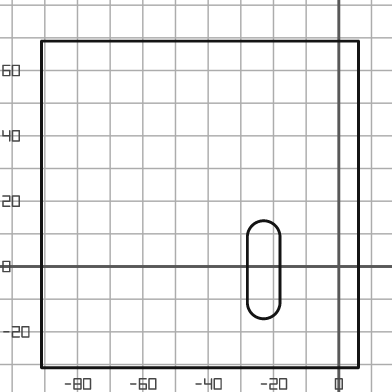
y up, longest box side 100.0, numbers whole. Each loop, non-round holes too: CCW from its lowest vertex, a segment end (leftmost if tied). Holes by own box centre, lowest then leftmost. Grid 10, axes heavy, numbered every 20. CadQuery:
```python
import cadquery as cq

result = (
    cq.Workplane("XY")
    .moveTo(-91.0, -31.0)
    .lineTo(6.0, -31.0)
    .lineTo(6.0, 69.0)
    .lineTo(-91.0, 69.0)
    .close()
    .moveTo(-28.0, -11.0)
    .threePointArc((-23.0, -16.0), (-18.0, -11.0))
    .lineTo(-18.0, 9.0)
    .threePointArc((-23.0, 14.0), (-28.0, 9.0))
    .close()
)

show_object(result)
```